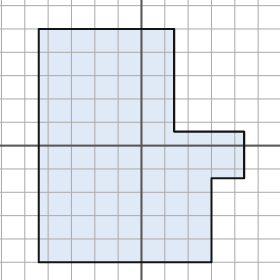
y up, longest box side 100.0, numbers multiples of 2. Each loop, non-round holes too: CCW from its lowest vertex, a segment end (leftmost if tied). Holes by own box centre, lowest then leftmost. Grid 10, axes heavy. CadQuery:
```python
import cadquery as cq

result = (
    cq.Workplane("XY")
    .moveTo(-44.0, -50.0)
    .lineTo(30.0, -50.0)
    .lineTo(30.0, -14.0)
    .lineTo(44.0, -14.0)
    .lineTo(44.0, 6.0)
    .lineTo(14.0, 6.0)
    .lineTo(14.0, 50.0)
    .lineTo(-44.0, 50.0)
    .close()
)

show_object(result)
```